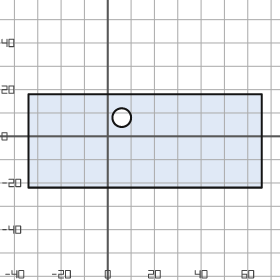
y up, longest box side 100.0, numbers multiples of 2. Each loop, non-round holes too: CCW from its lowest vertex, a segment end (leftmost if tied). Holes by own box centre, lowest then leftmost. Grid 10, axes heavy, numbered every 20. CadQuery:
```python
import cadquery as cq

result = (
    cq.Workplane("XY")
    .moveTo(-34.0, -22.0)
    .lineTo(66.0, -22.0)
    .lineTo(66.0, 18.0)
    .lineTo(-34.0, 18.0)
    .close()
    .moveTo(6.0, 8.0)
    .circle(4.0)
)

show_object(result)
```